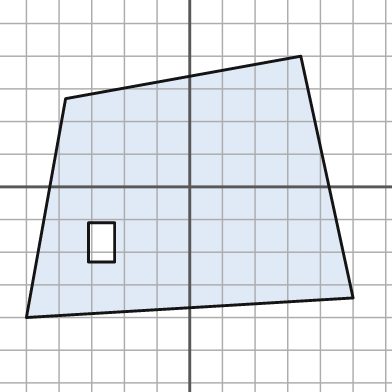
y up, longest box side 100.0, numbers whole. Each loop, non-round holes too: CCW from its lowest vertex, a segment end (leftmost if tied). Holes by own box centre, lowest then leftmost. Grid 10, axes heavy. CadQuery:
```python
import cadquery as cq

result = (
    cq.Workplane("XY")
    .moveTo(-50.0, -40.0)
    .lineTo(50.0, -34.0)
    .lineTo(34.0, 40.0)
    .lineTo(-38.0, 27.0)
    .close()
    .moveTo(-31.0, -23.0)
    .lineTo(-23.0, -23.0)
    .lineTo(-23.0, -11.0)
    .lineTo(-31.0, -11.0)
    .close()
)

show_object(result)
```